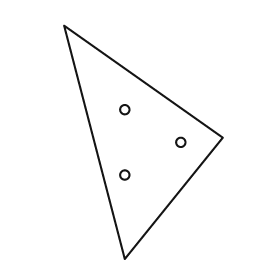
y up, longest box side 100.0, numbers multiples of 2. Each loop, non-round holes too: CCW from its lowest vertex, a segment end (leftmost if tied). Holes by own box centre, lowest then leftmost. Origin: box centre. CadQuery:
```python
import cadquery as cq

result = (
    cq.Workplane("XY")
    .moveTo(-8.0, -50.0)
    .lineTo(34.0, 2.0)
    .lineTo(-34.0, 50.0)
    .close()
    .moveTo(-8.0, -14.0)
    .circle(2.0)
    .moveTo(16.0, 0.0)
    .circle(2.0)
    .moveTo(-8.0, 14.0)
    .circle(2.0)
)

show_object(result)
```